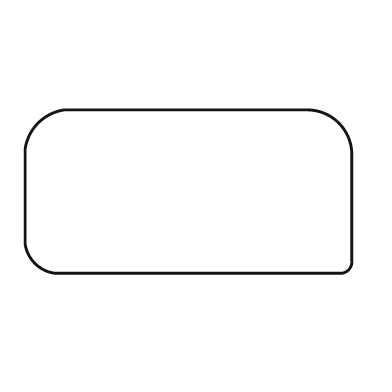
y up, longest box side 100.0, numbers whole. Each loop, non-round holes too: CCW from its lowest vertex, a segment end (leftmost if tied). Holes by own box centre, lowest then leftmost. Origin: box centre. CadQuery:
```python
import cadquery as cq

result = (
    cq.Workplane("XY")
    .moveTo(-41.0, -25.0)
    .lineTo(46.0, -25.0)
    .threePointArc((49.0, -24.0), (50.0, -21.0))
    .lineTo(50.0, 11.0)
    .threePointArc((46.0, 21.0), (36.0, 25.0))
    .lineTo(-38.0, 25.0)
    .threePointArc((-46.0, 21.0), (-50.0, 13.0))
    .lineTo(-50.0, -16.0)
    .threePointArc((-47.0, -22.0), (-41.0, -25.0))
    .close()
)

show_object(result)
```